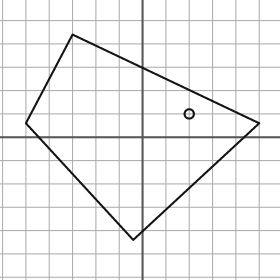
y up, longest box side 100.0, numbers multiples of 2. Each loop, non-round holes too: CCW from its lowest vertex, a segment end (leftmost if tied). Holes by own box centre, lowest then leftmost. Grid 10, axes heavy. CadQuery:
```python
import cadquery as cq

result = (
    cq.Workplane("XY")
    .moveTo(-4.0, -44.0)
    .lineTo(50.0, 6.0)
    .lineTo(-30.0, 44.0)
    .lineTo(-50.0, 6.0)
    .close()
    .moveTo(20.0, 10.0)
    .circle(2.0)
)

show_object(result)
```